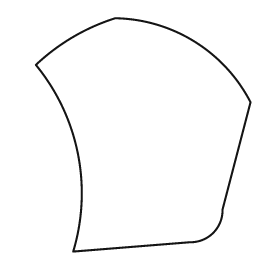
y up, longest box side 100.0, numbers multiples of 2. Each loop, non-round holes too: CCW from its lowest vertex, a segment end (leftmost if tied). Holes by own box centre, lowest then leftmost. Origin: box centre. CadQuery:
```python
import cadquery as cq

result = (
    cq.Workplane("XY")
    .moveTo(-30.0, -50.0)
    .lineTo(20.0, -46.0)
    .threePointArc((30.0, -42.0), (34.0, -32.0))
    .lineTo(46.0, 14.0)
    .threePointArc((22.0, 40.0), (-12.0, 50.0))
    .threePointArc((-30.0, 42.0), (-46.0, 30.0))
    .threePointArc((-28.0, -8.0), (-30.0, -50.0))
    .close()
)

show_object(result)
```